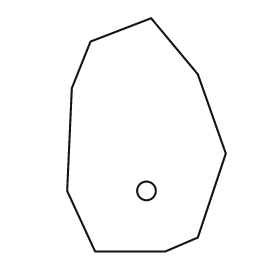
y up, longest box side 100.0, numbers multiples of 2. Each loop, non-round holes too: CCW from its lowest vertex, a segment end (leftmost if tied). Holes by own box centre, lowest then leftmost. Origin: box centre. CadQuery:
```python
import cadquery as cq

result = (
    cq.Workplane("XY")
    .moveTo(-22.0, -50.0)
    .lineTo(8.0, -50.0)
    .lineTo(22.0, -44.0)
    .lineTo(34.0, -8.0)
    .lineTo(22.0, 26.0)
    .lineTo(2.0, 50.0)
    .lineTo(-24.0, 40.0)
    .lineTo(-32.0, 20.0)
    .lineTo(-34.0, -24.0)
    .close()
    .moveTo(0.0, -24.0)
    .circle(4.0)
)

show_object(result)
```